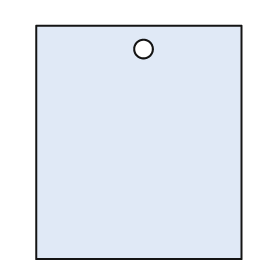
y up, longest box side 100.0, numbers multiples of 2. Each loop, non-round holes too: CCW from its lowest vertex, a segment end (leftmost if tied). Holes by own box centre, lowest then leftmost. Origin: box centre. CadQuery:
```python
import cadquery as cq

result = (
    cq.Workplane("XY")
    .moveTo(-44.0, -50.0)
    .lineTo(44.0, -50.0)
    .lineTo(44.0, 50.0)
    .lineTo(-44.0, 50.0)
    .close()
    .moveTo(2.0, 40.0)
    .circle(4.0)
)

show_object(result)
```